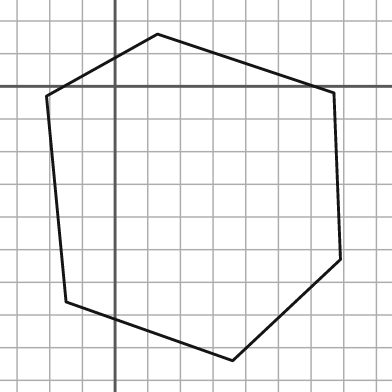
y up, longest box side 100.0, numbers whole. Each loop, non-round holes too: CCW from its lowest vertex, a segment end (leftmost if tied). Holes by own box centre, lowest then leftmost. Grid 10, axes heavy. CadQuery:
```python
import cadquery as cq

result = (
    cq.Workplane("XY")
    .moveTo(36.0, -84.0)
    .lineTo(69.0, -53.0)
    .lineTo(67.0, -2.0)
    .lineTo(13.0, 16.0)
    .lineTo(-21.0, -3.0)
    .lineTo(-15.0, -66.0)
    .close()
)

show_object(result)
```